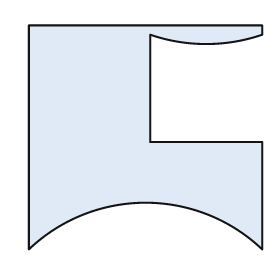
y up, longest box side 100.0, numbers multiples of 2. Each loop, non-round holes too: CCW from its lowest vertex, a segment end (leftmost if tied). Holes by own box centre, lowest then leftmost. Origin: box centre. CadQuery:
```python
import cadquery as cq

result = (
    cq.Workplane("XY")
    .moveTo(-50.0, -48.0)
    .threePointArc((0.0, -28.0), (50.0, -48.0))
    .lineTo(50.0, -2.0)
    .lineTo(2.0, -2.0)
    .lineTo(2.0, 44.0)
    .threePointArc((26.0, 40.0), (50.0, 44.0))
    .lineTo(50.0, 48.0)
    .lineTo(-50.0, 48.0)
    .close()
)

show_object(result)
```